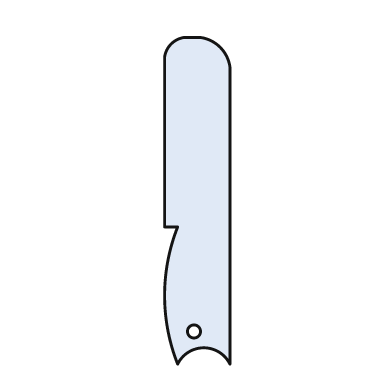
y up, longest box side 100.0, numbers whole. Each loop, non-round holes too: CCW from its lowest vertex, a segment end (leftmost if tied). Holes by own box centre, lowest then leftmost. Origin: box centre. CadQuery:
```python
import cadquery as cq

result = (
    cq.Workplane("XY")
    .moveTo(-6.0, -50.0)
    .threePointArc((2.0, -45.0), (10.0, -50.0))
    .lineTo(10.0, 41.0)
    .threePointArc((7.0, 47.0), (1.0, 50.0))
    .lineTo(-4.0, 50.0)
    .threePointArc((-8.0, 48.0), (-10.0, 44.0))
    .lineTo(-10.0, -8.0)
    .lineTo(-6.0, -8.0)
    .threePointArc((-10.0, -29.0), (-6.0, -50.0))
    .close()
    .moveTo(-1.0, -40.0)
    .circle(2.0)
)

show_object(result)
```